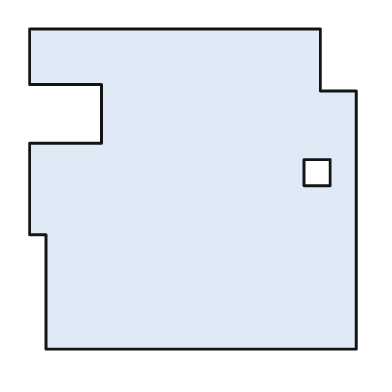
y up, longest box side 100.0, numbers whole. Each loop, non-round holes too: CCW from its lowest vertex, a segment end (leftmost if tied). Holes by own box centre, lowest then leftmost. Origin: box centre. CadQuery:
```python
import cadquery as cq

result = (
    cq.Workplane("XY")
    .moveTo(-45.0, -49.0)
    .lineTo(50.0, -49.0)
    .lineTo(50.0, 30.0)
    .lineTo(39.0, 30.0)
    .lineTo(39.0, 49.0)
    .lineTo(-50.0, 49.0)
    .lineTo(-50.0, 32.0)
    .lineTo(-28.0, 32.0)
    .lineTo(-28.0, 14.0)
    .lineTo(-50.0, 14.0)
    .lineTo(-50.0, -14.0)
    .lineTo(-45.0, -14.0)
    .close()
    .moveTo(34.0, 1.0)
    .lineTo(42.0, 1.0)
    .lineTo(42.0, 9.0)
    .lineTo(34.0, 9.0)
    .close()
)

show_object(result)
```